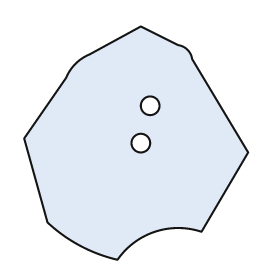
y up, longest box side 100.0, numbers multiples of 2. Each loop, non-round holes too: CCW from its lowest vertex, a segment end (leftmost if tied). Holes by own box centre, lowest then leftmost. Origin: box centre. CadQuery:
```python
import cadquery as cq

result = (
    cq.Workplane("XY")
    .moveTo(-8.0, -50.0)
    .threePointArc((8.0, -38.0), (28.0, -38.0))
    .lineTo(48.0, -4.0)
    .lineTo(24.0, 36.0)
    .threePointArc((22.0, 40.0), (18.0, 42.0))
    .lineTo(2.0, 50.0)
    .lineTo(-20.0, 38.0)
    .threePointArc((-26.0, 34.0), (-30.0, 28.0))
    .lineTo(-48.0, 2.0)
    .lineTo(-38.0, -34.0)
    .threePointArc((-24.0, -44.0), (-8.0, -50.0))
    .close()
    .moveTo(2.0, 0.0)
    .circle(4.0)
    .moveTo(6.0, 16.0)
    .circle(4.0)
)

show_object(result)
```